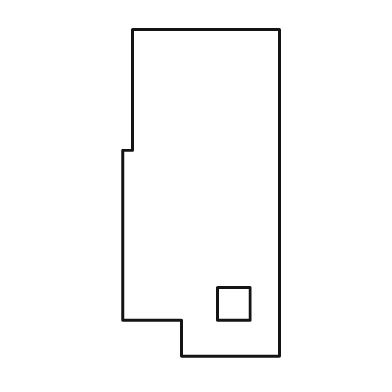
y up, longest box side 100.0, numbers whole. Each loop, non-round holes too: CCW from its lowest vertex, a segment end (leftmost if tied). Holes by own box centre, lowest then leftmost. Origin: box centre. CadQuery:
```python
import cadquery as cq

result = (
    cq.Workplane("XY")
    .moveTo(-6.0, -50.0)
    .lineTo(24.0, -50.0)
    .lineTo(24.0, 50.0)
    .lineTo(-21.0, 50.0)
    .lineTo(-21.0, 13.0)
    .lineTo(-24.0, 13.0)
    .lineTo(-24.0, -39.0)
    .lineTo(-6.0, -39.0)
    .close()
    .moveTo(5.0, -39.0)
    .lineTo(15.0, -39.0)
    .lineTo(15.0, -29.0)
    .lineTo(5.0, -29.0)
    .close()
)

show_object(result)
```